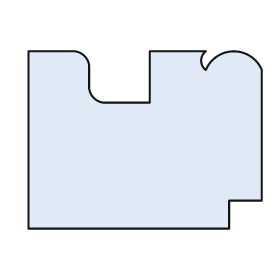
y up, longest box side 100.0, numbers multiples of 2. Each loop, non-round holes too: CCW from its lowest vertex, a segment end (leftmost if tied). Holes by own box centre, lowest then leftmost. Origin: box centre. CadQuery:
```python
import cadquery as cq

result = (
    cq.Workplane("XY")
    .moveTo(-50.0, -38.0)
    .lineTo(36.0, -38.0)
    .lineTo(36.0, -26.0)
    .lineTo(50.0, -26.0)
    .lineTo(50.0, 30.0)
    .threePointArc((38.0, 38.0), (26.0, 30.0))
    .threePointArc((24.0, 34.0), (26.0, 38.0))
    .lineTo(2.0, 38.0)
    .lineTo(2.0, 16.0)
    .lineTo(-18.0, 16.0)
    .threePointArc((-22.0, 18.0), (-24.0, 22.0))
    .lineTo(-24.0, 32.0)
    .threePointArc((-26.0, 36.0), (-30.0, 38.0))
    .lineTo(-50.0, 38.0)
    .close()
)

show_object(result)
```